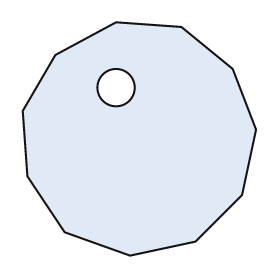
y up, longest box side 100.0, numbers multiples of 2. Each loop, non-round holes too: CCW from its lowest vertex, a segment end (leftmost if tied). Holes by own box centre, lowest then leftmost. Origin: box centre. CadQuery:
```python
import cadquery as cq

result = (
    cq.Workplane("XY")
    .moveTo(-4.0, -50.0)
    .lineTo(24.0, -44.0)
    .lineTo(44.0, -24.0)
    .lineTo(50.0, 4.0)
    .lineTo(40.0, 30.0)
    .lineTo(18.0, 48.0)
    .lineTo(-10.0, 50.0)
    .lineTo(-36.0, 36.0)
    .lineTo(-50.0, 12.0)
    .lineTo(-48.0, -16.0)
    .lineTo(-32.0, -40.0)
    .close()
    .moveTo(-10.0, 22.0)
    .circle(8.0)
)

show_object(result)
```